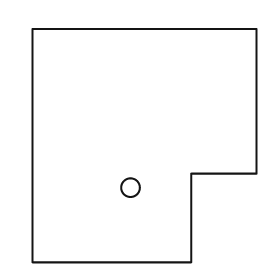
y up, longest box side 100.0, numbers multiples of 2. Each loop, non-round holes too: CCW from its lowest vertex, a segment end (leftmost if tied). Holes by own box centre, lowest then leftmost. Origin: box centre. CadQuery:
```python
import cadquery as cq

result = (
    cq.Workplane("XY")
    .moveTo(-48.0, -50.0)
    .lineTo(20.0, -50.0)
    .lineTo(20.0, -12.0)
    .lineTo(48.0, -12.0)
    .lineTo(48.0, 50.0)
    .lineTo(-48.0, 50.0)
    .close()
    .moveTo(-6.0, -18.0)
    .circle(4.0)
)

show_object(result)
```